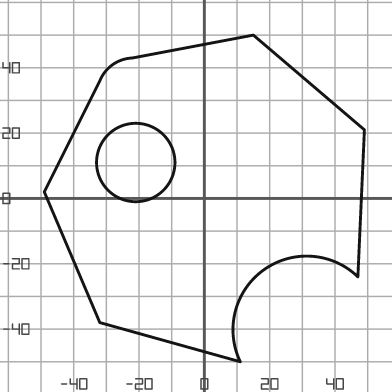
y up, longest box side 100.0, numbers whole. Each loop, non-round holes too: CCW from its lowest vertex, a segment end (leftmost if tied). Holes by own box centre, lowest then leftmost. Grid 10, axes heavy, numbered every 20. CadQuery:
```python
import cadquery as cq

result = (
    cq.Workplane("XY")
    .moveTo(11.0, -50.0)
    .threePointArc((18.0, -22.0), (47.0, -24.0))
    .lineTo(49.0, 21.0)
    .lineTo(15.0, 50.0)
    .lineTo(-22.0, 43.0)
    .threePointArc((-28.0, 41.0), (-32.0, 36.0))
    .lineTo(-49.0, 2.0)
    .lineTo(-32.0, -38.0)
    .close()
    .moveTo(-21.0, 11.0)
    .circle(12.0)
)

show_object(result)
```